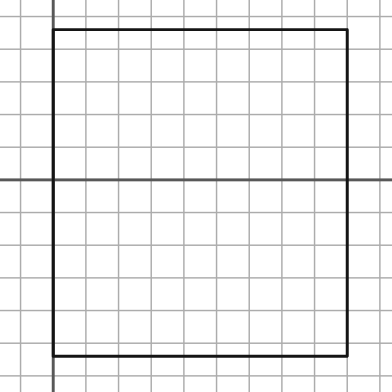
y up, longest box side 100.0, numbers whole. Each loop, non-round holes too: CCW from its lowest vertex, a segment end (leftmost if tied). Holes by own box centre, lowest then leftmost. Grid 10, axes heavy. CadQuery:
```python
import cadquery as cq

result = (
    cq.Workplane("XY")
    .moveTo(0.0, -54.0)
    .lineTo(90.0, -54.0)
    .lineTo(90.0, 46.0)
    .lineTo(0.0, 46.0)
    .close()
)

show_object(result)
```